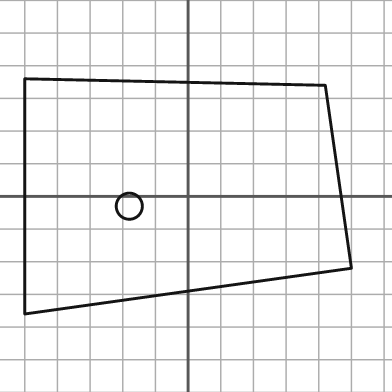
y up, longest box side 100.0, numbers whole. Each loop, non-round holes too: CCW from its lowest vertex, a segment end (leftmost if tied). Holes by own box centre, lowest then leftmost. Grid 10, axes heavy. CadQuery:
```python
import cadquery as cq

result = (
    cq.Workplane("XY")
    .moveTo(-50.0, -36.0)
    .lineTo(50.0, -22.0)
    .lineTo(42.0, 34.0)
    .lineTo(-50.0, 36.0)
    .close()
    .moveTo(-18.0, -3.0)
    .circle(4.0)
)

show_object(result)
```